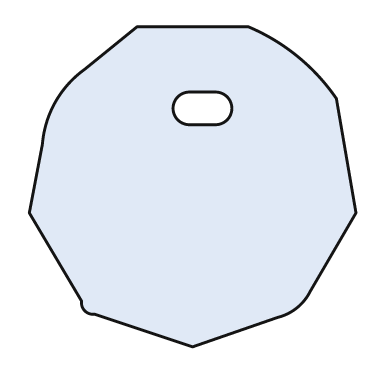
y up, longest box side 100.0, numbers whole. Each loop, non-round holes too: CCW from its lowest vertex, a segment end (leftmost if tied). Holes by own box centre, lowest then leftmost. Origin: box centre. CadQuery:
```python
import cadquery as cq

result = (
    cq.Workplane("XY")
    .moveTo(0.0, -49.0)
    .lineTo(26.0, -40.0)
    .threePointArc((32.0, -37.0), (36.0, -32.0))
    .lineTo(50.0, -8.0)
    .lineTo(44.0, 27.0)
    .threePointArc((32.0, 40.0), (17.0, 49.0))
    .lineTo(-17.0, 49.0)
    .lineTo(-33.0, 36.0)
    .threePointArc((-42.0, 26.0), (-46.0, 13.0))
    .lineTo(-50.0, -8.0)
    .lineTo(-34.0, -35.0)
    .threePointArc((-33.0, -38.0), (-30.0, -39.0))
    .close()
    .moveTo(-1.0, 19.0)
    .lineTo(7.0, 19.0)
    .threePointArc((12.0, 24.0), (7.0, 29.0))
    .lineTo(-1.0, 29.0)
    .threePointArc((-6.0, 24.0), (-1.0, 19.0))
    .close()
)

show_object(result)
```